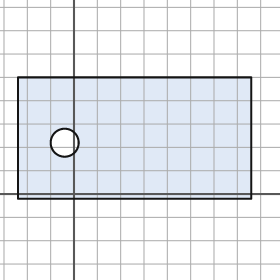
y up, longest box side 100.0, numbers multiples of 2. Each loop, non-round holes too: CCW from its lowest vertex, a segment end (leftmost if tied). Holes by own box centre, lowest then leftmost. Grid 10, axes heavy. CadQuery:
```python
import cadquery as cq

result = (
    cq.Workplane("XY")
    .moveTo(-24.0, -2.0)
    .lineTo(76.0, -2.0)
    .lineTo(76.0, 50.0)
    .lineTo(-24.0, 50.0)
    .close()
    .moveTo(-4.0, 22.0)
    .circle(6.0)
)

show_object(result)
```